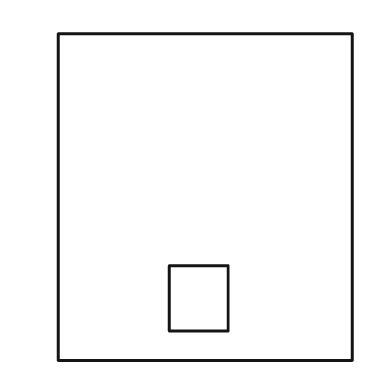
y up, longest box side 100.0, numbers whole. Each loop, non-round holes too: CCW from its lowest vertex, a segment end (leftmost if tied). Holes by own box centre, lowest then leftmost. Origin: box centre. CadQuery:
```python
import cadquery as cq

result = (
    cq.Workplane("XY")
    .moveTo(-45.0, -50.0)
    .lineTo(45.0, -50.0)
    .lineTo(45.0, 50.0)
    .lineTo(-45.0, 50.0)
    .close()
    .moveTo(-11.0, -41.0)
    .lineTo(7.0, -41.0)
    .lineTo(7.0, -21.0)
    .lineTo(-11.0, -21.0)
    .close()
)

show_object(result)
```